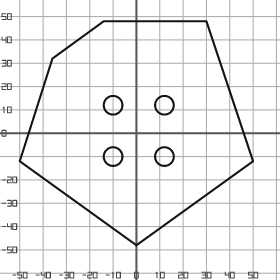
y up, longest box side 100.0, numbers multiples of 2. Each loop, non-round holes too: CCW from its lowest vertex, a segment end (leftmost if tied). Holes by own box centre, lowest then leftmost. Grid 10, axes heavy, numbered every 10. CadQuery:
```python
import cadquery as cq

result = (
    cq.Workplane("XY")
    .moveTo(0.0, -48.0)
    .lineTo(50.0, -12.0)
    .lineTo(30.0, 48.0)
    .lineTo(-14.0, 48.0)
    .lineTo(-36.0, 32.0)
    .lineTo(-50.0, -12.0)
    .close()
    .moveTo(-10.0, -10.0)
    .circle(4.0)
    .moveTo(12.0, -10.0)
    .circle(4.0)
    .moveTo(-10.0, 12.0)
    .circle(4.0)
    .moveTo(12.0, 12.0)
    .circle(4.0)
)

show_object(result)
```